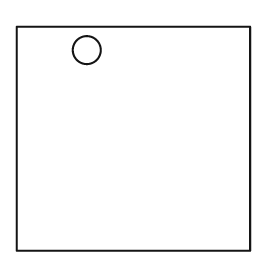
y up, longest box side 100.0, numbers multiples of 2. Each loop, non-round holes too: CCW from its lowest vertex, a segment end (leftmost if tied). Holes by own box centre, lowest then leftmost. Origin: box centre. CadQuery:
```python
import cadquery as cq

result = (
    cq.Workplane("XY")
    .moveTo(-50.0, -48.0)
    .lineTo(50.0, -48.0)
    .lineTo(50.0, 48.0)
    .lineTo(-50.0, 48.0)
    .close()
    .moveTo(-20.0, 38.0)
    .circle(6.0)
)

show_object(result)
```